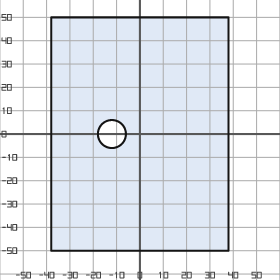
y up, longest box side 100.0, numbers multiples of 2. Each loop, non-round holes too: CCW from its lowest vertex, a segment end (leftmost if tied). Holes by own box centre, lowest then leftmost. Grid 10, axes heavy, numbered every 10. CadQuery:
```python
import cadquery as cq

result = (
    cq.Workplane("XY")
    .moveTo(-38.0, -50.0)
    .lineTo(38.0, -50.0)
    .lineTo(38.0, 50.0)
    .lineTo(-38.0, 50.0)
    .close()
    .moveTo(-12.0, 0.0)
    .circle(6.0)
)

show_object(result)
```